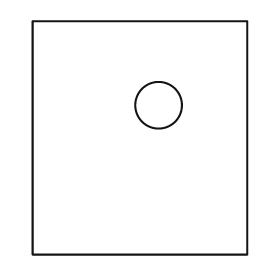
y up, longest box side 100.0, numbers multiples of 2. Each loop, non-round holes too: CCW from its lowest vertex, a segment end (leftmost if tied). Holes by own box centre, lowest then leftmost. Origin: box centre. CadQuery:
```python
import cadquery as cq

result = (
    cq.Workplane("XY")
    .moveTo(-46.0, -50.0)
    .lineTo(46.0, -50.0)
    .lineTo(46.0, 50.0)
    .lineTo(-46.0, 50.0)
    .close()
    .moveTo(8.0, 14.0)
    .circle(10.0)
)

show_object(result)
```